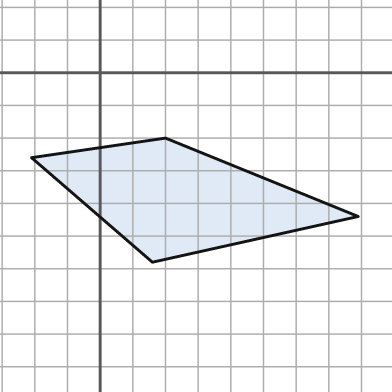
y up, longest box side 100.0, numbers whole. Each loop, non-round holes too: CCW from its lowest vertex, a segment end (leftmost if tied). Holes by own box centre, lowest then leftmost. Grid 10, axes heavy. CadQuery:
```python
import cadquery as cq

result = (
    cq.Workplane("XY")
    .moveTo(16.0, -58.0)
    .lineTo(79.0, -44.0)
    .lineTo(20.0, -20.0)
    .lineTo(-21.0, -26.0)
    .close()
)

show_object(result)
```